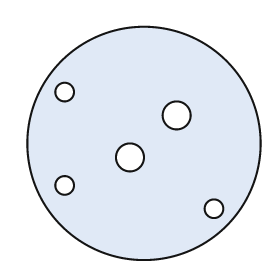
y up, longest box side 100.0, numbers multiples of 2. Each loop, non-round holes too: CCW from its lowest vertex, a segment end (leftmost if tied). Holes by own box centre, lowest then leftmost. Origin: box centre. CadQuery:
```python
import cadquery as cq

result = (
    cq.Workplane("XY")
    .moveTo(0.0, 0.0)
    .circle(50.0)
    .moveTo(30.0, -28.0)
    .circle(4.0)
    .moveTo(-34.0, -18.0)
    .circle(4.0)
    .moveTo(-6.0, -6.0)
    .circle(6.0)
    .moveTo(14.0, 12.0)
    .circle(6.0)
    .moveTo(-34.0, 22.0)
    .circle(4.0)
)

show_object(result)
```